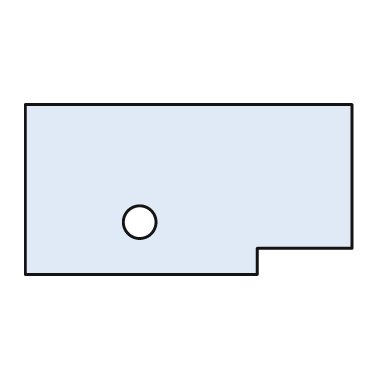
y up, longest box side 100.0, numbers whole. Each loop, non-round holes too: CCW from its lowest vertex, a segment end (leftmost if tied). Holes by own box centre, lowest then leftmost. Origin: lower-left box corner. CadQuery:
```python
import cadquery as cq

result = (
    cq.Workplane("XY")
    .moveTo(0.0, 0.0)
    .lineTo(71.0, 0.0)
    .lineTo(71.0, 8.0)
    .lineTo(100.0, 8.0)
    .lineTo(100.0, 52.0)
    .lineTo(0.0, 52.0)
    .close()
    .moveTo(35.0, 16.0)
    .circle(5.0)
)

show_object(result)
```